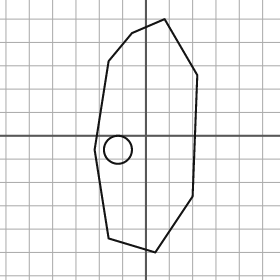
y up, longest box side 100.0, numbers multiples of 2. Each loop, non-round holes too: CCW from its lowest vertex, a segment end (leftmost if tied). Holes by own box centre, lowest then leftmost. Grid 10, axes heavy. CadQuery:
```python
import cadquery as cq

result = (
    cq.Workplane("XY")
    .moveTo(4.0, -50.0)
    .lineTo(20.0, -26.0)
    .lineTo(22.0, 26.0)
    .lineTo(8.0, 50.0)
    .lineTo(-6.0, 44.0)
    .lineTo(-16.0, 32.0)
    .lineTo(-22.0, -6.0)
    .lineTo(-16.0, -44.0)
    .close()
    .moveTo(-12.0, -6.0)
    .circle(6.0)
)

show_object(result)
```